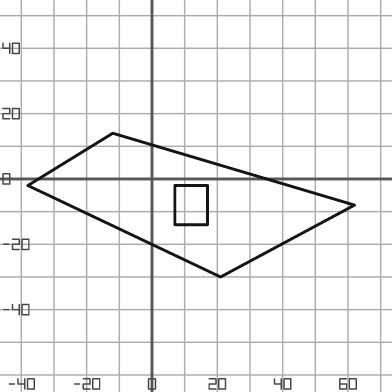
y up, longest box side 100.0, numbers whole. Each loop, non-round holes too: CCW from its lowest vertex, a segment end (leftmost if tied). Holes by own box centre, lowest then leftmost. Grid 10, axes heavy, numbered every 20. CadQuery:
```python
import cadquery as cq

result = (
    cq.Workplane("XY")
    .moveTo(21.0, -30.0)
    .lineTo(62.0, -8.0)
    .lineTo(-12.0, 14.0)
    .lineTo(-38.0, -2.0)
    .close()
    .moveTo(7.0, -14.0)
    .lineTo(17.0, -14.0)
    .lineTo(17.0, -2.0)
    .lineTo(7.0, -2.0)
    .close()
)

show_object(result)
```